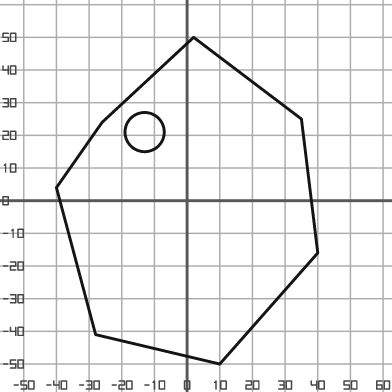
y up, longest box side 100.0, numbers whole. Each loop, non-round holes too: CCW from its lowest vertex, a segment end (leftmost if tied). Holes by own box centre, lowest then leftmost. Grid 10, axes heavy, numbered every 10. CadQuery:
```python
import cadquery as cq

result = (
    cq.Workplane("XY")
    .moveTo(10.0, -50.0)
    .lineTo(40.0, -16.0)
    .lineTo(35.0, 25.0)
    .lineTo(2.0, 50.0)
    .lineTo(-26.0, 24.0)
    .lineTo(-40.0, 4.0)
    .lineTo(-28.0, -41.0)
    .close()
    .moveTo(-13.0, 21.0)
    .circle(6.0)
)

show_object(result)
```